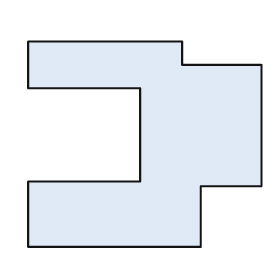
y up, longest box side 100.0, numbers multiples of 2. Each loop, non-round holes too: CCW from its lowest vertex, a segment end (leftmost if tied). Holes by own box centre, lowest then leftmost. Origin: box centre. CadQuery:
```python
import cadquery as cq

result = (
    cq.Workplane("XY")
    .moveTo(-50.0, -44.0)
    .lineTo(24.0, -44.0)
    .lineTo(24.0, -18.0)
    .lineTo(50.0, -18.0)
    .lineTo(50.0, 34.0)
    .lineTo(16.0, 34.0)
    .lineTo(16.0, 44.0)
    .lineTo(-50.0, 44.0)
    .lineTo(-50.0, 24.0)
    .lineTo(-2.0, 24.0)
    .lineTo(-2.0, -16.0)
    .lineTo(-50.0, -16.0)
    .close()
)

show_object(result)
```